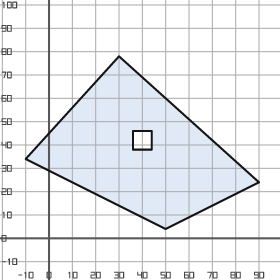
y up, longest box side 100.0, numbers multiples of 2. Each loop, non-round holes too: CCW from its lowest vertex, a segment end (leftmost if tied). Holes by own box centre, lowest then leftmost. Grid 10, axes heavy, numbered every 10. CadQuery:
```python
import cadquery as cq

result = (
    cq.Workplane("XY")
    .moveTo(50.0, 4.0)
    .lineTo(90.0, 24.0)
    .lineTo(30.0, 78.0)
    .lineTo(-10.0, 34.0)
    .close()
    .moveTo(36.0, 38.0)
    .lineTo(44.0, 38.0)
    .lineTo(44.0, 46.0)
    .lineTo(36.0, 46.0)
    .close()
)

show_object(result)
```